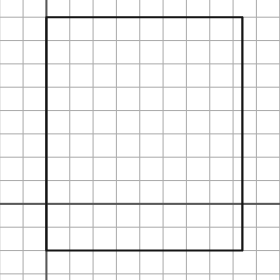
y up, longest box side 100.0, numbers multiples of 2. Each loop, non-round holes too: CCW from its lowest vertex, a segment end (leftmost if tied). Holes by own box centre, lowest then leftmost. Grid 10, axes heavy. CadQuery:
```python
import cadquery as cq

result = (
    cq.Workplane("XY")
    .moveTo(0.0, -20.0)
    .lineTo(84.0, -20.0)
    .lineTo(84.0, 80.0)
    .lineTo(0.0, 80.0)
    .close()
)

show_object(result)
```